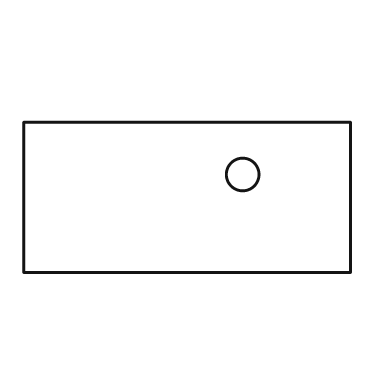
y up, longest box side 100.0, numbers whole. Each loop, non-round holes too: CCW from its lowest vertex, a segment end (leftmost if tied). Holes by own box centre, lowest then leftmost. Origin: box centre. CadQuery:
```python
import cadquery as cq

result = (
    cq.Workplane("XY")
    .moveTo(-50.0, -23.0)
    .lineTo(50.0, -23.0)
    .lineTo(50.0, 23.0)
    .lineTo(-50.0, 23.0)
    .close()
    .moveTo(17.0, 7.0)
    .circle(5.0)
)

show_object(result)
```